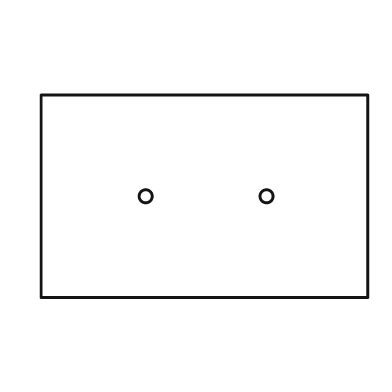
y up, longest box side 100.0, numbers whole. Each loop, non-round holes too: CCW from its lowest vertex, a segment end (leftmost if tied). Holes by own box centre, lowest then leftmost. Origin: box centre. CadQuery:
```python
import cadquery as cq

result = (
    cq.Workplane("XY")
    .moveTo(-50.0, -31.0)
    .lineTo(50.0, -31.0)
    .lineTo(50.0, 31.0)
    .lineTo(-50.0, 31.0)
    .close()
    .moveTo(-18.0, 0.0)
    .circle(2.0)
    .moveTo(19.0, 0.0)
    .circle(2.0)
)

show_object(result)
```